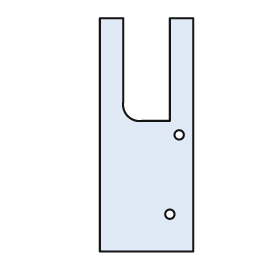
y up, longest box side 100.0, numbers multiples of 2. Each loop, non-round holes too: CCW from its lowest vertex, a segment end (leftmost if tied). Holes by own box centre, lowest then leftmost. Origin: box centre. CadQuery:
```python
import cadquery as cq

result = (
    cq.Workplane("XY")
    .moveTo(-20.0, -50.0)
    .lineTo(20.0, -50.0)
    .lineTo(20.0, 50.0)
    .lineTo(10.0, 50.0)
    .lineTo(10.0, 6.0)
    .lineTo(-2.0, 6.0)
    .threePointArc((-8.0, 8.0), (-10.0, 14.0))
    .lineTo(-10.0, 50.0)
    .lineTo(-20.0, 50.0)
    .close()
    .moveTo(10.0, -34.0)
    .circle(2.0)
    .moveTo(14.0, 0.0)
    .circle(2.0)
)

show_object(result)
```